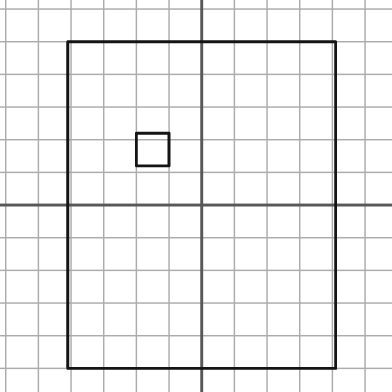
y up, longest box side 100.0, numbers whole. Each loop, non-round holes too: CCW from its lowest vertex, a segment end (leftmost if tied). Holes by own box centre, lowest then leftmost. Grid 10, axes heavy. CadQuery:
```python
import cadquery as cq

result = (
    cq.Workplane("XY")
    .moveTo(-41.0, -50.0)
    .lineTo(41.0, -50.0)
    .lineTo(41.0, 50.0)
    .lineTo(-41.0, 50.0)
    .close()
    .moveTo(-20.0, 12.0)
    .lineTo(-10.0, 12.0)
    .lineTo(-10.0, 22.0)
    .lineTo(-20.0, 22.0)
    .close()
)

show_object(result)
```